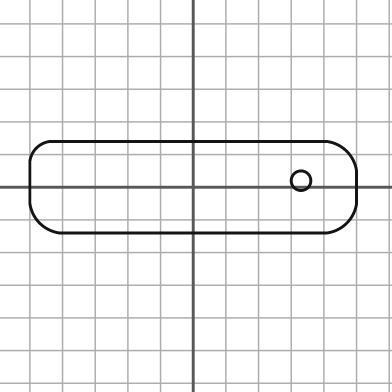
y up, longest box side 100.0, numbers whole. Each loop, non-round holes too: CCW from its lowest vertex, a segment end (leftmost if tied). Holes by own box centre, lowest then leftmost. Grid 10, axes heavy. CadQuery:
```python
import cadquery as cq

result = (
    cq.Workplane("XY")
    .moveTo(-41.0, -14.0)
    .lineTo(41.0, -14.0)
    .threePointArc((47.0, -11.0), (50.0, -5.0))
    .lineTo(50.0, 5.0)
    .threePointArc((47.0, 11.0), (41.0, 14.0))
    .lineTo(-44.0, 14.0)
    .threePointArc((-48.0, 12.0), (-50.0, 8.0))
    .lineTo(-50.0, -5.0)
    .threePointArc((-47.0, -11.0), (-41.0, -14.0))
    .close()
    .moveTo(33.0, 2.0)
    .circle(3.0)
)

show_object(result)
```